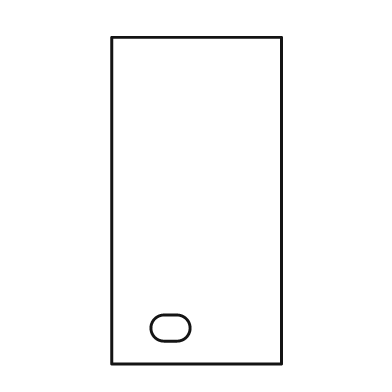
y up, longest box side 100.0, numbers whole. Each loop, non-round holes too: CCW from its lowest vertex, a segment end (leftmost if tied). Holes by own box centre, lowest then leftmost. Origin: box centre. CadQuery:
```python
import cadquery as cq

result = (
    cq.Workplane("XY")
    .moveTo(-26.0, -50.0)
    .lineTo(26.0, -50.0)
    .lineTo(26.0, 50.0)
    .lineTo(-26.0, 50.0)
    .close()
    .moveTo(-10.0, -43.0)
    .lineTo(-6.0, -43.0)
    .threePointArc((-2.0, -39.0), (-6.0, -35.0))
    .lineTo(-10.0, -35.0)
    .threePointArc((-14.0, -39.0), (-10.0, -43.0))
    .close()
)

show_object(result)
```